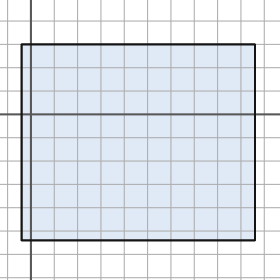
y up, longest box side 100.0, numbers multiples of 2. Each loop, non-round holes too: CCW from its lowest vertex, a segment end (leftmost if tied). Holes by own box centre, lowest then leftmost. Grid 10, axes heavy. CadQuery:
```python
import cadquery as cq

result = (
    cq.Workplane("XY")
    .moveTo(-4.0, -54.0)
    .lineTo(96.0, -54.0)
    .lineTo(96.0, 30.0)
    .lineTo(-4.0, 30.0)
    .close()
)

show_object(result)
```